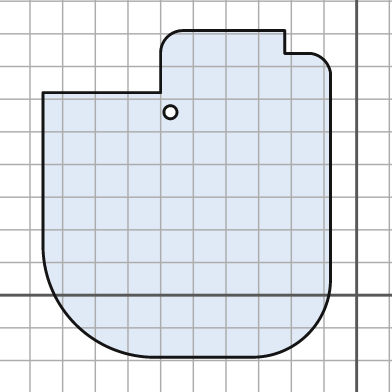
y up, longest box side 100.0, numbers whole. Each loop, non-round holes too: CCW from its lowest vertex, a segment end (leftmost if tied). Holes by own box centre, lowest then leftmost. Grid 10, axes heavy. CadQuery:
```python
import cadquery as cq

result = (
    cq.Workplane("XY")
    .moveTo(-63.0, -19.0)
    .lineTo(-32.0, -19.0)
    .threePointArc((-15.0, -12.0), (-8.0, 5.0))
    .lineTo(-8.0, 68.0)
    .threePointArc((-10.0, 72.0), (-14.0, 74.0))
    .lineTo(-22.0, 74.0)
    .lineTo(-22.0, 81.0)
    .lineTo(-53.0, 81.0)
    .threePointArc((-58.0, 79.0), (-60.0, 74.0))
    .lineTo(-60.0, 62.0)
    .lineTo(-96.0, 62.0)
    .lineTo(-96.0, 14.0)
    .threePointArc((-86.0, -9.0), (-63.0, -19.0))
    .close()
    .moveTo(-57.0, 56.0)
    .circle(2.0)
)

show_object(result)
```